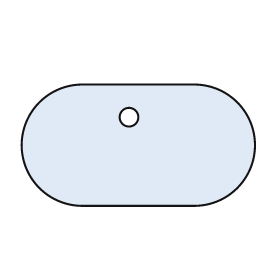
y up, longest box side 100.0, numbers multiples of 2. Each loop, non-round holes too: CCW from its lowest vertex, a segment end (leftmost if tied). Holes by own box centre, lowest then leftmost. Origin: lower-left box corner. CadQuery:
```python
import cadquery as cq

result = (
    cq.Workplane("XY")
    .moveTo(26.0, 0.0)
    .lineTo(74.0, 0.0)
    .threePointArc((100.0, 26.0), (74.0, 52.0))
    .lineTo(26.0, 52.0)
    .threePointArc((0.0, 26.0), (26.0, 0.0))
    .close()
    .moveTo(46.0, 38.0)
    .circle(4.0)
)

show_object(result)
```